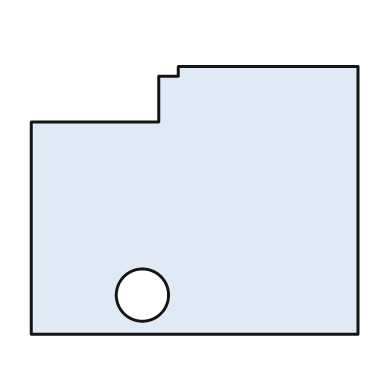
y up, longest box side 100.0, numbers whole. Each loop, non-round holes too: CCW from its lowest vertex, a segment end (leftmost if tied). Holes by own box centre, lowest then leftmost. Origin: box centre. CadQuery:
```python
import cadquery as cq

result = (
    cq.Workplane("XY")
    .moveTo(-50.0, -41.0)
    .lineTo(50.0, -41.0)
    .lineTo(50.0, 41.0)
    .lineTo(-5.0, 41.0)
    .lineTo(-5.0, 38.0)
    .lineTo(-11.0, 38.0)
    .lineTo(-11.0, 24.0)
    .lineTo(-50.0, 24.0)
    .close()
    .moveTo(-16.0, -29.0)
    .circle(8.0)
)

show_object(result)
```